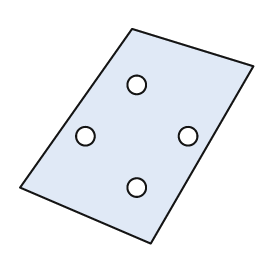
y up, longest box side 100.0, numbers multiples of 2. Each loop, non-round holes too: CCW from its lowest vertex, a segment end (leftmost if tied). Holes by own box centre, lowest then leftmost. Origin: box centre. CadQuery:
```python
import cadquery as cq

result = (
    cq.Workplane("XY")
    .moveTo(6.0, -46.0)
    .lineTo(50.0, 30.0)
    .lineTo(-2.0, 46.0)
    .lineTo(-50.0, -22.0)
    .close()
    .moveTo(0.0, -22.0)
    .circle(4.0)
    .moveTo(-22.0, 0.0)
    .circle(4.0)
    .moveTo(22.0, 0.0)
    .circle(4.0)
    .moveTo(0.0, 22.0)
    .circle(4.0)
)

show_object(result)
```